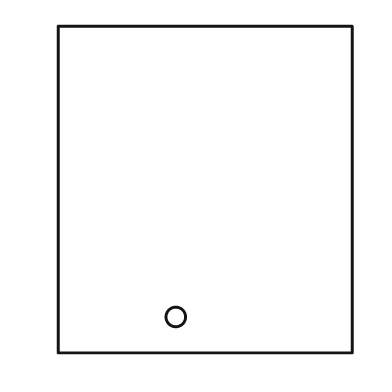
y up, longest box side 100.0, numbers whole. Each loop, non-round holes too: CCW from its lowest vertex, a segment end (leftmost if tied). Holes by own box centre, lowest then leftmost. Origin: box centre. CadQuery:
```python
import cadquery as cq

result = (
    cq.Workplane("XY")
    .moveTo(-45.0, -50.0)
    .lineTo(45.0, -50.0)
    .lineTo(45.0, 50.0)
    .lineTo(-45.0, 50.0)
    .close()
    .moveTo(-9.0, -39.0)
    .circle(3.0)
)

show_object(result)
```